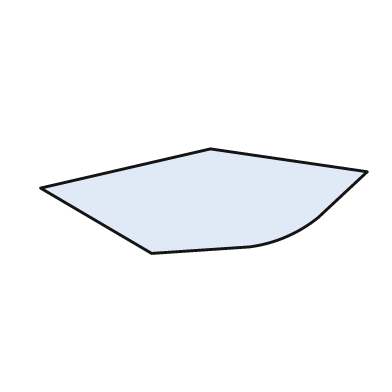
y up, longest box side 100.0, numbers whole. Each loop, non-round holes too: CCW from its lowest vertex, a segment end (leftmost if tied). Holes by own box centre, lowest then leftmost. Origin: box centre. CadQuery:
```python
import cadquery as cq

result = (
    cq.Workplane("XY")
    .moveTo(-16.0, -16.0)
    .lineTo(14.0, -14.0)
    .threePointArc((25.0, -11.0), (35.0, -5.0))
    .lineTo(50.0, 9.0)
    .lineTo(2.0, 16.0)
    .lineTo(-50.0, 4.0)
    .close()
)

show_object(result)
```